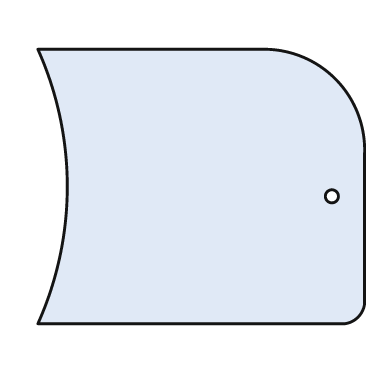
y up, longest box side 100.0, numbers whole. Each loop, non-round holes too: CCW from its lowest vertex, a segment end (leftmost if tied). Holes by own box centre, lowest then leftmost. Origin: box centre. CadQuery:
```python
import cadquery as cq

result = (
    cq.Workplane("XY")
    .moveTo(-50.0, -42.0)
    .lineTo(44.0, -42.0)
    .threePointArc((48.0, -40.0), (50.0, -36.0))
    .lineTo(50.0, 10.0)
    .threePointArc((41.0, 33.0), (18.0, 42.0))
    .lineTo(-50.0, 42.0)
    .threePointArc((-41.0, 0.0), (-50.0, -42.0))
    .close()
    .moveTo(40.0, -3.0)
    .circle(2.0)
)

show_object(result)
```